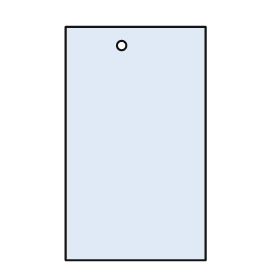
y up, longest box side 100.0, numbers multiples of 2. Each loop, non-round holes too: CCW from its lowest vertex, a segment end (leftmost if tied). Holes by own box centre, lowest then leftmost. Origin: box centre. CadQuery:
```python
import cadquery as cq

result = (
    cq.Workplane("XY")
    .moveTo(-30.0, -50.0)
    .lineTo(30.0, -50.0)
    .lineTo(30.0, 50.0)
    .lineTo(-30.0, 50.0)
    .close()
    .moveTo(-6.0, 42.0)
    .circle(2.0)
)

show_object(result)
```